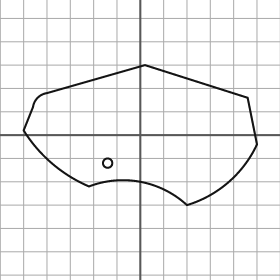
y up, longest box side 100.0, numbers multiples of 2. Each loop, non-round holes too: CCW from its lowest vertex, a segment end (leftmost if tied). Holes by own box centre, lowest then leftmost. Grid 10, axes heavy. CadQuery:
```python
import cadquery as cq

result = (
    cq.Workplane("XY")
    .moveTo(20.0, -30.0)
    .threePointArc((38.0, -20.0), (50.0, -4.0))
    .lineTo(46.0, 16.0)
    .lineTo(2.0, 30.0)
    .lineTo(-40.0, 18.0)
    .threePointArc((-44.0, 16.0), (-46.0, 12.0))
    .lineTo(-50.0, 2.0)
    .threePointArc((-38.0, -12.0), (-22.0, -22.0))
    .threePointArc((0.0, -20.0), (20.0, -30.0))
    .close()
    .moveTo(-14.0, -12.0)
    .circle(2.0)
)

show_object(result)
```